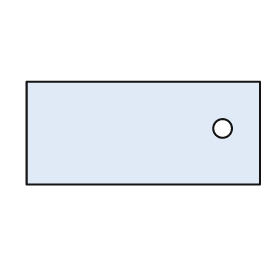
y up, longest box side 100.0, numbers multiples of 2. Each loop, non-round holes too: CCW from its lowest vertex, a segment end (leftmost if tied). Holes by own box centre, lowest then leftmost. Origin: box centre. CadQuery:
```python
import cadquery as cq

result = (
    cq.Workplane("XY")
    .moveTo(-50.0, -22.0)
    .lineTo(50.0, -22.0)
    .lineTo(50.0, 22.0)
    .lineTo(-50.0, 22.0)
    .close()
    .moveTo(34.0, 2.0)
    .circle(4.0)
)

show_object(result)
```